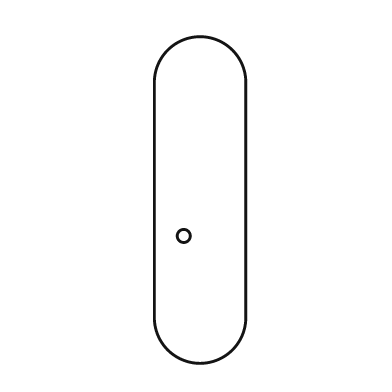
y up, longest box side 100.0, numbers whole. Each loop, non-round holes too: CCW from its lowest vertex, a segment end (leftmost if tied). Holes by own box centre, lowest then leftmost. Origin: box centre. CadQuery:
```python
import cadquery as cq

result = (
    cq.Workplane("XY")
    .moveTo(-14.0, -36.0)
    .threePointArc((0.0, -50.0), (14.0, -36.0))
    .lineTo(14.0, 36.0)
    .threePointArc((0.0, 50.0), (-14.0, 36.0))
    .close()
    .moveTo(-5.0, -11.0)
    .circle(2.0)
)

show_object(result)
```